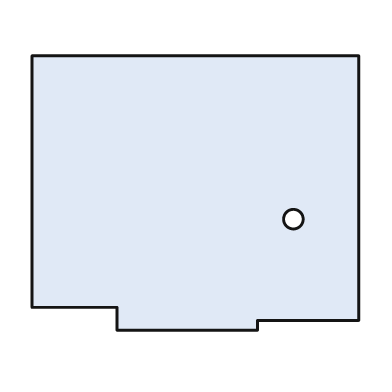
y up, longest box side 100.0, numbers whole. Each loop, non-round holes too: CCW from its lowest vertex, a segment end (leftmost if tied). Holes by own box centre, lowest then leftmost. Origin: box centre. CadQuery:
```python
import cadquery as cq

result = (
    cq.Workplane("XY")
    .moveTo(-24.0, -42.0)
    .lineTo(19.0, -42.0)
    .lineTo(19.0, -39.0)
    .lineTo(50.0, -39.0)
    .lineTo(50.0, 42.0)
    .lineTo(-50.0, 42.0)
    .lineTo(-50.0, -35.0)
    .lineTo(-24.0, -35.0)
    .close()
    .moveTo(30.0, -8.0)
    .circle(3.0)
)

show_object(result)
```